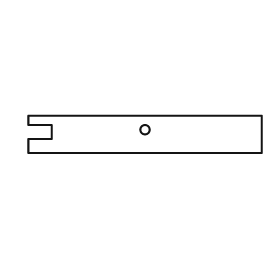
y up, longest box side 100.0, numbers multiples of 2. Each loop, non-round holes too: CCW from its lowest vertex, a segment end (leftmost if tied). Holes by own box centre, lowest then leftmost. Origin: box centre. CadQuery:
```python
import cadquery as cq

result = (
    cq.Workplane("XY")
    .moveTo(-50.0, -8.0)
    .lineTo(50.0, -8.0)
    .lineTo(50.0, 8.0)
    .lineTo(-50.0, 8.0)
    .lineTo(-50.0, 4.0)
    .lineTo(-40.0, 4.0)
    .lineTo(-40.0, -2.0)
    .lineTo(-50.0, -2.0)
    .close()
    .moveTo(0.0, 2.0)
    .circle(2.0)
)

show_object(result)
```